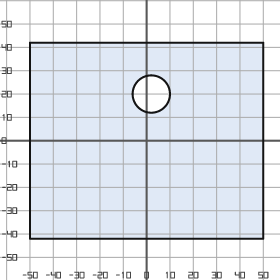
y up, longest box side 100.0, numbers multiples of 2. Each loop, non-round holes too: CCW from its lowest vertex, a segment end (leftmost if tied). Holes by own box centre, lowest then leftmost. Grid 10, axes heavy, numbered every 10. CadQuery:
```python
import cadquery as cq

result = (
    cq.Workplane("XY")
    .moveTo(-50.0, -42.0)
    .lineTo(50.0, -42.0)
    .lineTo(50.0, 42.0)
    .lineTo(-50.0, 42.0)
    .close()
    .moveTo(2.0, 20.0)
    .circle(8.0)
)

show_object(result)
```